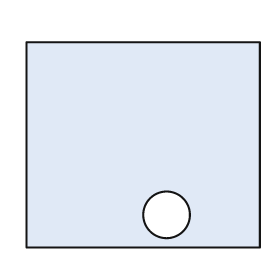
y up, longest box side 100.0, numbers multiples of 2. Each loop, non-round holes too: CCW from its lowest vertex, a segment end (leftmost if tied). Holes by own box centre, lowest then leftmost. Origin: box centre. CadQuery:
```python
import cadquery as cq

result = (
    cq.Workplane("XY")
    .moveTo(-50.0, -44.0)
    .lineTo(50.0, -44.0)
    .lineTo(50.0, 44.0)
    .lineTo(-50.0, 44.0)
    .close()
    .moveTo(10.0, -30.0)
    .circle(10.0)
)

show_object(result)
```